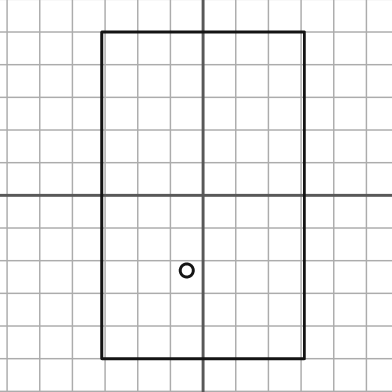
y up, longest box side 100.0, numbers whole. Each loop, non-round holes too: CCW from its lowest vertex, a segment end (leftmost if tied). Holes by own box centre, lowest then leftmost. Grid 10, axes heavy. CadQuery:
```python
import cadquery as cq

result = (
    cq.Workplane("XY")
    .moveTo(-31.0, -50.0)
    .lineTo(31.0, -50.0)
    .lineTo(31.0, 50.0)
    .lineTo(-31.0, 50.0)
    .close()
    .moveTo(-5.0, -23.0)
    .circle(2.0)
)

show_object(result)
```